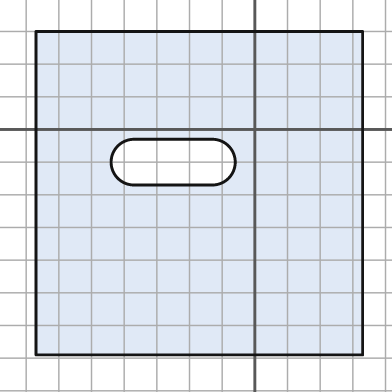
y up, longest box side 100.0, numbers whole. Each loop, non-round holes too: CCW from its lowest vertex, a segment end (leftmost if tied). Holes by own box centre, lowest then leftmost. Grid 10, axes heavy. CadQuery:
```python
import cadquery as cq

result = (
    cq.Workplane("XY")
    .moveTo(-67.0, -69.0)
    .lineTo(33.0, -69.0)
    .lineTo(33.0, 30.0)
    .lineTo(-67.0, 30.0)
    .close()
    .moveTo(-37.0, -17.0)
    .lineTo(-13.0, -17.0)
    .threePointArc((-6.0, -10.0), (-13.0, -3.0))
    .lineTo(-37.0, -3.0)
    .threePointArc((-44.0, -10.0), (-37.0, -17.0))
    .close()
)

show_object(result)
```